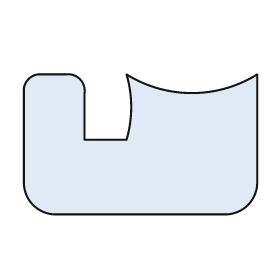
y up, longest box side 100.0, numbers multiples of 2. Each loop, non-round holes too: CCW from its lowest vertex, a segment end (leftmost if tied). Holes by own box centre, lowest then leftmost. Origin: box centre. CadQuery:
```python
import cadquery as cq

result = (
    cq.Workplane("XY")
    .moveTo(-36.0, -30.0)
    .lineTo(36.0, -30.0)
    .threePointArc((46.0, -26.0), (50.0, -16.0))
    .lineTo(50.0, 30.0)
    .threePointArc((22.0, 22.0), (-6.0, 30.0))
    .threePointArc((-4.0, 16.0), (-6.0, 2.0))
    .lineTo(-24.0, 2.0)
    .lineTo(-24.0, 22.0)
    .threePointArc((-26.0, 28.0), (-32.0, 30.0))
    .lineTo(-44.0, 30.0)
    .threePointArc((-48.0, 28.0), (-50.0, 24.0))
    .lineTo(-50.0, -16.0)
    .threePointArc((-46.0, -26.0), (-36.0, -30.0))
    .close()
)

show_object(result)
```